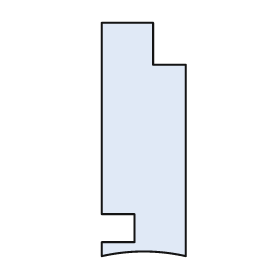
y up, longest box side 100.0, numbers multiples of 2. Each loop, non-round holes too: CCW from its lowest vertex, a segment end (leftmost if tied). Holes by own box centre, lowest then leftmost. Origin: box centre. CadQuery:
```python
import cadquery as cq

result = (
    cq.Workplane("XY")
    .moveTo(-18.0, -50.0)
    .threePointArc((0.0, -48.0), (18.0, -50.0))
    .lineTo(18.0, 32.0)
    .lineTo(4.0, 32.0)
    .lineTo(4.0, 50.0)
    .lineTo(-18.0, 50.0)
    .lineTo(-18.0, -32.0)
    .lineTo(-4.0, -32.0)
    .lineTo(-4.0, -44.0)
    .lineTo(-18.0, -44.0)
    .close()
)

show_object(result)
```